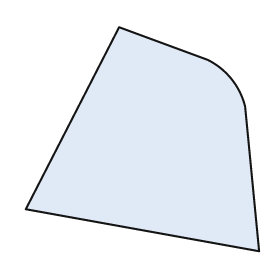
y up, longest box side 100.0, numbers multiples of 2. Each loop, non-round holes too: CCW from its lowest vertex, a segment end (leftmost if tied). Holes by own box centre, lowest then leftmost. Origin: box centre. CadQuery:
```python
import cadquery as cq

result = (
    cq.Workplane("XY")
    .moveTo(50.0, -48.0)
    .lineTo(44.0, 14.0)
    .threePointArc((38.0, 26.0), (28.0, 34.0))
    .lineTo(-10.0, 48.0)
    .lineTo(-50.0, -30.0)
    .close()
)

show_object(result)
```